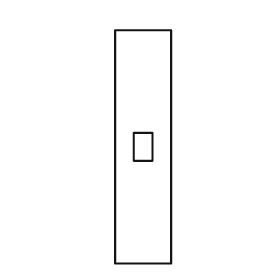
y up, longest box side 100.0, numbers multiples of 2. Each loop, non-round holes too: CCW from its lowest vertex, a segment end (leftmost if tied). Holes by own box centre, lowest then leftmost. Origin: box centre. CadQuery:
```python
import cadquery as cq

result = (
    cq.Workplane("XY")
    .moveTo(-12.0, -50.0)
    .lineTo(12.0, -50.0)
    .lineTo(12.0, 50.0)
    .lineTo(-12.0, 50.0)
    .close()
    .moveTo(-4.0, -6.0)
    .lineTo(4.0, -6.0)
    .lineTo(4.0, 6.0)
    .lineTo(-4.0, 6.0)
    .close()
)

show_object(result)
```